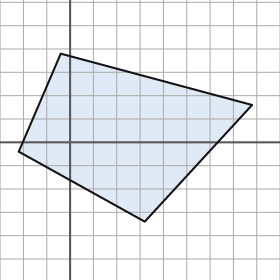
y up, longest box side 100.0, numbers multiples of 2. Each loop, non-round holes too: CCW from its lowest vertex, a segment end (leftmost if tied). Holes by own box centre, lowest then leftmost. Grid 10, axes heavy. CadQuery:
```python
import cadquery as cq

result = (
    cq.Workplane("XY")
    .moveTo(32.0, -34.0)
    .lineTo(78.0, 16.0)
    .lineTo(-4.0, 38.0)
    .lineTo(-22.0, -4.0)
    .close()
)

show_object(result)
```